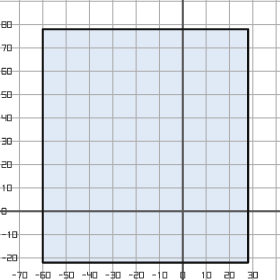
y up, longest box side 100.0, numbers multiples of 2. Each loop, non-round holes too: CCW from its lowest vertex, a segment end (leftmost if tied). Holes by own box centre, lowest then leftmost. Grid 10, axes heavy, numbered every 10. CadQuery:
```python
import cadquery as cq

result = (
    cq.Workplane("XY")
    .moveTo(-60.0, -22.0)
    .lineTo(28.0, -22.0)
    .lineTo(28.0, 78.0)
    .lineTo(-60.0, 78.0)
    .close()
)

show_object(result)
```